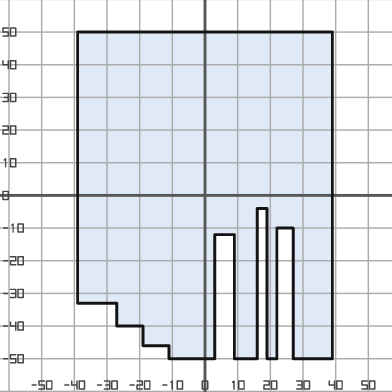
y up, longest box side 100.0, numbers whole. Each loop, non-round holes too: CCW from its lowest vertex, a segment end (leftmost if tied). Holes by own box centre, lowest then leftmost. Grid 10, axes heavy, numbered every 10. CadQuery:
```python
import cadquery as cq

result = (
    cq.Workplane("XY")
    .moveTo(-11.0, -50.0)
    .lineTo(3.0, -50.0)
    .lineTo(3.0, -12.0)
    .lineTo(9.0, -12.0)
    .lineTo(9.0, -50.0)
    .lineTo(16.0, -50.0)
    .lineTo(16.0, -4.0)
    .lineTo(19.0, -4.0)
    .lineTo(19.0, -50.0)
    .lineTo(22.0, -50.0)
    .lineTo(22.0, -10.0)
    .lineTo(27.0, -10.0)
    .lineTo(27.0, -50.0)
    .lineTo(39.0, -50.0)
    .lineTo(39.0, 50.0)
    .lineTo(-39.0, 50.0)
    .lineTo(-39.0, -33.0)
    .lineTo(-27.0, -33.0)
    .lineTo(-27.0, -40.0)
    .lineTo(-19.0, -40.0)
    .lineTo(-19.0, -46.0)
    .lineTo(-11.0, -46.0)
    .close()
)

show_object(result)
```